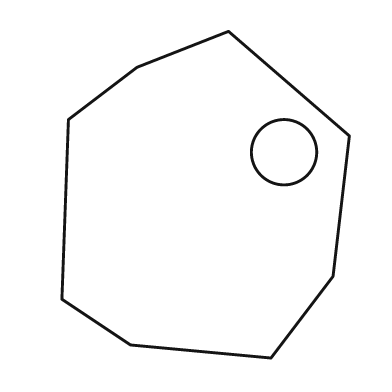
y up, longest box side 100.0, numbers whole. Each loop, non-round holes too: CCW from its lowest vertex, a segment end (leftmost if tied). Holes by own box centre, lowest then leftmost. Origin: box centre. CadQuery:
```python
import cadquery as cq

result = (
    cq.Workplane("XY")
    .moveTo(20.0, -50.0)
    .lineTo(39.0, -25.0)
    .lineTo(44.0, 18.0)
    .lineTo(7.0, 50.0)
    .lineTo(-21.0, 39.0)
    .lineTo(-42.0, 23.0)
    .lineTo(-44.0, -32.0)
    .lineTo(-23.0, -46.0)
    .close()
    .moveTo(24.0, 13.0)
    .circle(10.0)
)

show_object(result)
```